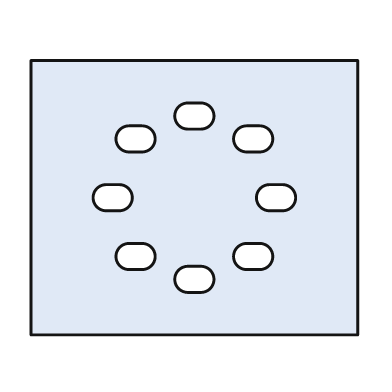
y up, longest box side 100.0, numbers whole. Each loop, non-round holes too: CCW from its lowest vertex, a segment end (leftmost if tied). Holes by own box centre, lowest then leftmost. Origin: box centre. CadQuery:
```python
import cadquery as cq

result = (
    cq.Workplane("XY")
    .moveTo(-50.0, -42.0)
    .lineTo(50.0, -42.0)
    .lineTo(50.0, 42.0)
    .lineTo(-50.0, 42.0)
    .close()
    .moveTo(-2.0, -29.0)
    .lineTo(2.0, -29.0)
    .threePointArc((6.0, -25.0), (2.0, -21.0))
    .lineTo(-2.0, -21.0)
    .threePointArc((-6.0, -25.0), (-2.0, -29.0))
    .close()
    .moveTo(-20.0, -22.0)
    .lineTo(-16.0, -22.0)
    .threePointArc((-12.0, -18.0), (-16.0, -14.0))
    .lineTo(-20.0, -14.0)
    .threePointArc((-24.0, -18.0), (-20.0, -22.0))
    .close()
    .moveTo(16.0, -22.0)
    .lineTo(20.0, -22.0)
    .threePointArc((24.0, -18.0), (20.0, -14.0))
    .lineTo(16.0, -14.0)
    .threePointArc((12.0, -18.0), (16.0, -22.0))
    .close()
    .moveTo(-27.0, -4.0)
    .lineTo(-23.0, -4.0)
    .threePointArc((-19.0, 0.0), (-23.0, 4.0))
    .lineTo(-27.0, 4.0)
    .threePointArc((-31.0, 0.0), (-27.0, -4.0))
    .close()
    .moveTo(23.0, -4.0)
    .lineTo(27.0, -4.0)
    .threePointArc((31.0, 0.0), (27.0, 4.0))
    .lineTo(23.0, 4.0)
    .threePointArc((19.0, 0.0), (23.0, -4.0))
    .close()
    .moveTo(-20.0, 14.0)
    .lineTo(-16.0, 14.0)
    .threePointArc((-12.0, 18.0), (-16.0, 22.0))
    .lineTo(-20.0, 22.0)
    .threePointArc((-24.0, 18.0), (-20.0, 14.0))
    .close()
    .moveTo(16.0, 14.0)
    .lineTo(20.0, 14.0)
    .threePointArc((24.0, 18.0), (20.0, 22.0))
    .lineTo(16.0, 22.0)
    .threePointArc((12.0, 18.0), (16.0, 14.0))
    .close()
    .moveTo(-2.0, 21.0)
    .lineTo(2.0, 21.0)
    .threePointArc((6.0, 25.0), (2.0, 29.0))
    .lineTo(-2.0, 29.0)
    .threePointArc((-6.0, 25.0), (-2.0, 21.0))
    .close()
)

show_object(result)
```